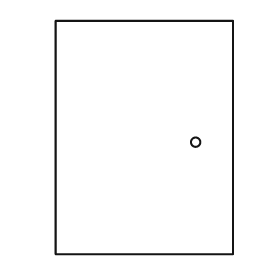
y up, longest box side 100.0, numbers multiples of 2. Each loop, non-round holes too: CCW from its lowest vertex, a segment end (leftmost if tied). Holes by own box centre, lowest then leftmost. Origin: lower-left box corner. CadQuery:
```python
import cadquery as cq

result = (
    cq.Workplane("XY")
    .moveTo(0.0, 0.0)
    .lineTo(76.0, 0.0)
    .lineTo(76.0, 100.0)
    .lineTo(0.0, 100.0)
    .close()
    .moveTo(60.0, 48.0)
    .circle(2.0)
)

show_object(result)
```